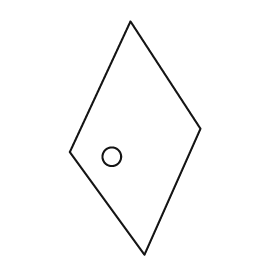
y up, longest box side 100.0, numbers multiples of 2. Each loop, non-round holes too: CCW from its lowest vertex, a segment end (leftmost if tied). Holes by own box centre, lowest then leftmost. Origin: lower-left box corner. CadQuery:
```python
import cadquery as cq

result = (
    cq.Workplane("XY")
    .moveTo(32.0, 0.0)
    .lineTo(56.0, 54.0)
    .lineTo(26.0, 100.0)
    .lineTo(0.0, 44.0)
    .close()
    .moveTo(18.0, 42.0)
    .circle(4.0)
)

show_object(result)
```